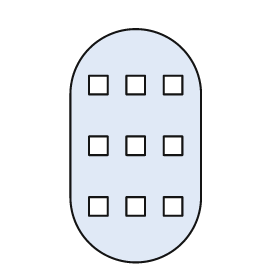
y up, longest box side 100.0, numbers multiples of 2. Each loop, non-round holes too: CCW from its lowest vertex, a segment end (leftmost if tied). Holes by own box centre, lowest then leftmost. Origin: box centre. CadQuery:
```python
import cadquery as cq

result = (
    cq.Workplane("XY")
    .moveTo(-28.0, -22.0)
    .threePointArc((0.0, -50.0), (28.0, -22.0))
    .lineTo(28.0, 22.0)
    .threePointArc((0.0, 50.0), (-28.0, 22.0))
    .close()
    .moveTo(-20.0, -30.0)
    .lineTo(-12.0, -30.0)
    .lineTo(-12.0, -22.0)
    .lineTo(-20.0, -22.0)
    .close()
    .moveTo(-4.0, -30.0)
    .lineTo(4.0, -30.0)
    .lineTo(4.0, -22.0)
    .lineTo(-4.0, -22.0)
    .close()
    .moveTo(12.0, -30.0)
    .lineTo(20.0, -30.0)
    .lineTo(20.0, -22.0)
    .lineTo(12.0, -22.0)
    .close()
    .moveTo(-20.0, -4.0)
    .lineTo(-12.0, -4.0)
    .lineTo(-12.0, 4.0)
    .lineTo(-20.0, 4.0)
    .close()
    .moveTo(-4.0, -4.0)
    .lineTo(4.0, -4.0)
    .lineTo(4.0, 4.0)
    .lineTo(-4.0, 4.0)
    .close()
    .moveTo(12.0, -4.0)
    .lineTo(20.0, -4.0)
    .lineTo(20.0, 4.0)
    .lineTo(12.0, 4.0)
    .close()
    .moveTo(-20.0, 22.0)
    .lineTo(-12.0, 22.0)
    .lineTo(-12.0, 30.0)
    .lineTo(-20.0, 30.0)
    .close()
    .moveTo(-4.0, 22.0)
    .lineTo(4.0, 22.0)
    .lineTo(4.0, 30.0)
    .lineTo(-4.0, 30.0)
    .close()
    .moveTo(12.0, 22.0)
    .lineTo(20.0, 22.0)
    .lineTo(20.0, 30.0)
    .lineTo(12.0, 30.0)
    .close()
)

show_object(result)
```